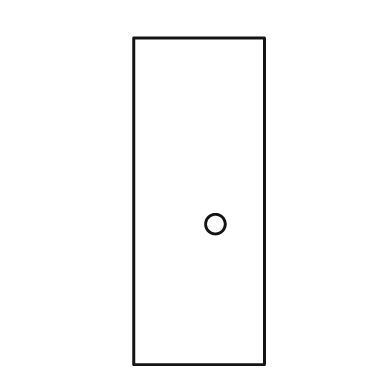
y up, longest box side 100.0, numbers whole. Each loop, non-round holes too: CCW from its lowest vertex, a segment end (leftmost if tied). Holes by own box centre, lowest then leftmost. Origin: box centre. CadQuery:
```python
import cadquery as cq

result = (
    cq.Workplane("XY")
    .moveTo(-20.0, -50.0)
    .lineTo(20.0, -50.0)
    .lineTo(20.0, 50.0)
    .lineTo(-20.0, 50.0)
    .close()
    .moveTo(5.0, -7.0)
    .circle(3.0)
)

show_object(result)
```